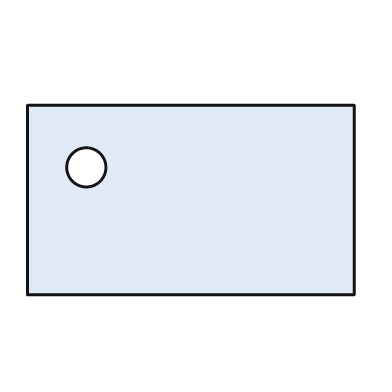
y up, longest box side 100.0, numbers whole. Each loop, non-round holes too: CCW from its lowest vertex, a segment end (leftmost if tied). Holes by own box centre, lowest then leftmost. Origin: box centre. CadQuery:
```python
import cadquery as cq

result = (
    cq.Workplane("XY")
    .moveTo(-50.0, -29.0)
    .lineTo(50.0, -29.0)
    .lineTo(50.0, 29.0)
    .lineTo(-50.0, 29.0)
    .close()
    .moveTo(-32.0, 10.0)
    .circle(6.0)
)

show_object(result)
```